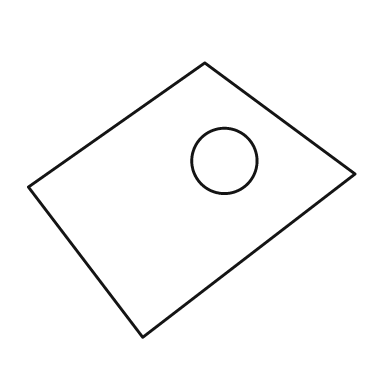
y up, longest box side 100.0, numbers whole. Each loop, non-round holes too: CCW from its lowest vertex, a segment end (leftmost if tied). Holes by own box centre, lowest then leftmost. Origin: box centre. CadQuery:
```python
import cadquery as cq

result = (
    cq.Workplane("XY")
    .moveTo(-15.0, -42.0)
    .lineTo(50.0, 8.0)
    .lineTo(4.0, 42.0)
    .lineTo(-50.0, 4.0)
    .close()
    .moveTo(10.0, 12.0)
    .circle(10.0)
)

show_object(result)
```